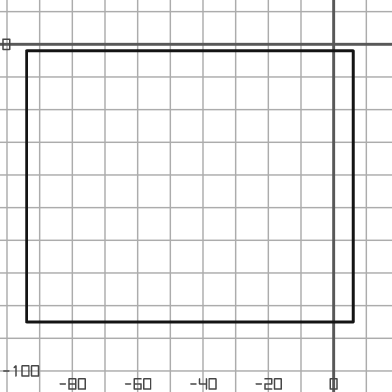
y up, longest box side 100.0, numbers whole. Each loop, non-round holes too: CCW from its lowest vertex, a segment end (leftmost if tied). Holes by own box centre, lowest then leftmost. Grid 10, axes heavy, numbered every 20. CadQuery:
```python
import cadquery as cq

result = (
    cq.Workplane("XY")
    .moveTo(-94.0, -85.0)
    .lineTo(6.0, -85.0)
    .lineTo(6.0, -2.0)
    .lineTo(-94.0, -2.0)
    .close()
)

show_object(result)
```